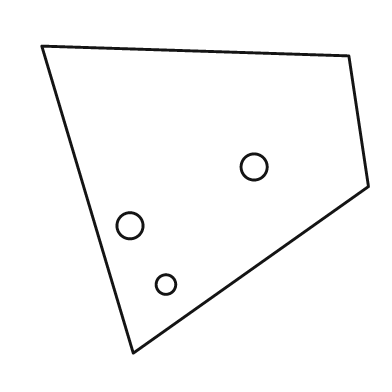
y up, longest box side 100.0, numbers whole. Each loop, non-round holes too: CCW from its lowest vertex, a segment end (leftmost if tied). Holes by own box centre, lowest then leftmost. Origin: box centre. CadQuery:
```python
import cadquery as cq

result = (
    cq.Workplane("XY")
    .moveTo(-22.0, -47.0)
    .lineTo(50.0, 4.0)
    .lineTo(44.0, 44.0)
    .lineTo(-50.0, 47.0)
    .close()
    .moveTo(-12.0, -26.0)
    .circle(3.0)
    .moveTo(-23.0, -8.0)
    .circle(4.0)
    .moveTo(15.0, 10.0)
    .circle(4.0)
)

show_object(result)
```